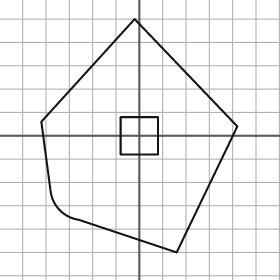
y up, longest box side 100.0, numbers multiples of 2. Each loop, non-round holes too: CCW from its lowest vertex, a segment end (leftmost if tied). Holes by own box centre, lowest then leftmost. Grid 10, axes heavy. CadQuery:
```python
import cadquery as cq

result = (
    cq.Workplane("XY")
    .moveTo(16.0, -50.0)
    .lineTo(42.0, 4.0)
    .lineTo(-2.0, 50.0)
    .lineTo(-42.0, 6.0)
    .lineTo(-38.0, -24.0)
    .threePointArc((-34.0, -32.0), (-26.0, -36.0))
    .close()
    .moveTo(-8.0, -8.0)
    .lineTo(8.0, -8.0)
    .lineTo(8.0, 8.0)
    .lineTo(-8.0, 8.0)
    .close()
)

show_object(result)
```